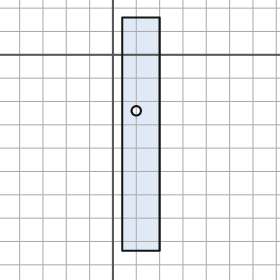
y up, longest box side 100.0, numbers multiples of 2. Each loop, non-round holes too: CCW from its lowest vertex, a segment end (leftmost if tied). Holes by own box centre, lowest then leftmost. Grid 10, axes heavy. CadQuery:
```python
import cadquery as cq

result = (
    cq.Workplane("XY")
    .moveTo(4.0, -84.0)
    .lineTo(20.0, -84.0)
    .lineTo(20.0, 16.0)
    .lineTo(4.0, 16.0)
    .close()
    .moveTo(10.0, -24.0)
    .circle(2.0)
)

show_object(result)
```